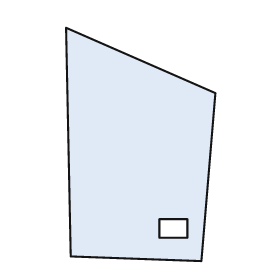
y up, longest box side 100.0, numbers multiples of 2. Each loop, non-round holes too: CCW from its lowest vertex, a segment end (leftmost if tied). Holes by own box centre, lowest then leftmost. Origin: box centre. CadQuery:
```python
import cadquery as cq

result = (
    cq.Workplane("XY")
    .moveTo(26.0, -50.0)
    .lineTo(32.0, 22.0)
    .lineTo(-32.0, 50.0)
    .lineTo(-30.0, -48.0)
    .close()
    .moveTo(8.0, -40.0)
    .lineTo(20.0, -40.0)
    .lineTo(20.0, -32.0)
    .lineTo(8.0, -32.0)
    .close()
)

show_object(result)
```